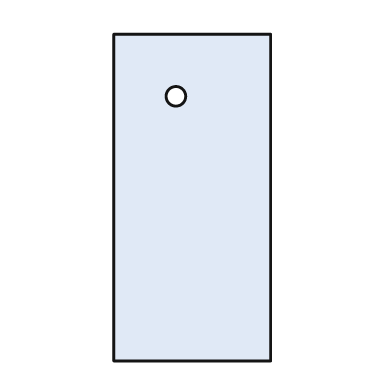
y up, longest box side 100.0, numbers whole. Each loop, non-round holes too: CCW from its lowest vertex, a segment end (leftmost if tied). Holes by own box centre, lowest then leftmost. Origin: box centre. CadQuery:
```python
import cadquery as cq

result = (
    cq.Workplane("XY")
    .moveTo(-24.0, -50.0)
    .lineTo(24.0, -50.0)
    .lineTo(24.0, 50.0)
    .lineTo(-24.0, 50.0)
    .close()
    .moveTo(-5.0, 31.0)
    .circle(3.0)
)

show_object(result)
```